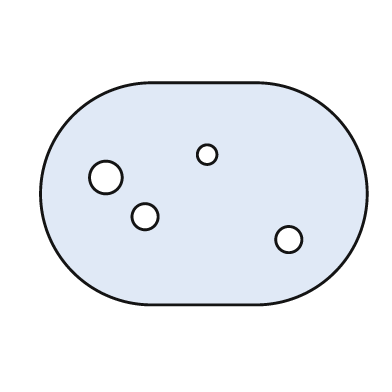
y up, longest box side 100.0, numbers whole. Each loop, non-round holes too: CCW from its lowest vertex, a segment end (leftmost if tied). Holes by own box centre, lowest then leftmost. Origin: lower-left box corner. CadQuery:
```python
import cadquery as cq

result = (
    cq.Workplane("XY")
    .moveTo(34.0, 0.0)
    .lineTo(66.0, 0.0)
    .threePointArc((100.0, 34.0), (66.0, 68.0))
    .lineTo(34.0, 68.0)
    .threePointArc((0.0, 34.0), (34.0, 0.0))
    .close()
    .moveTo(76.0, 20.0)
    .circle(4.0)
    .moveTo(32.0, 27.0)
    .circle(4.0)
    .moveTo(20.0, 39.0)
    .circle(5.0)
    .moveTo(51.0, 46.0)
    .circle(3.0)
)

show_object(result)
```